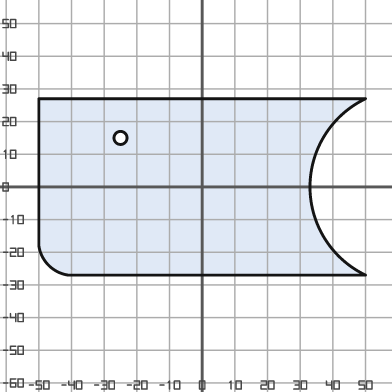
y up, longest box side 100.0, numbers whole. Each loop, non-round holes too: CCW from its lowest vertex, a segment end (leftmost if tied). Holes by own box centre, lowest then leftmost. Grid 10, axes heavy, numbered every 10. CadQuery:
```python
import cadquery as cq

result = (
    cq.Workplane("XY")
    .moveTo(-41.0, -27.0)
    .lineTo(50.0, -27.0)
    .threePointArc((33.0, 0.0), (50.0, 27.0))
    .lineTo(-50.0, 27.0)
    .lineTo(-50.0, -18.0)
    .threePointArc((-47.0, -24.0), (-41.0, -27.0))
    .close()
    .moveTo(-25.0, 15.0)
    .circle(2.0)
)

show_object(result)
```